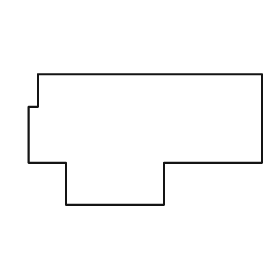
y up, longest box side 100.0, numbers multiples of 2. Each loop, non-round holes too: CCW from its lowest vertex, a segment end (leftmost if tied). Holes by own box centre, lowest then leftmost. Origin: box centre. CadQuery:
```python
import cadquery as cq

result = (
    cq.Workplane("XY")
    .moveTo(-34.0, -28.0)
    .lineTo(8.0, -28.0)
    .lineTo(8.0, -10.0)
    .lineTo(50.0, -10.0)
    .lineTo(50.0, 28.0)
    .lineTo(-46.0, 28.0)
    .lineTo(-46.0, 14.0)
    .lineTo(-50.0, 14.0)
    .lineTo(-50.0, -10.0)
    .lineTo(-34.0, -10.0)
    .close()
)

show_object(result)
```